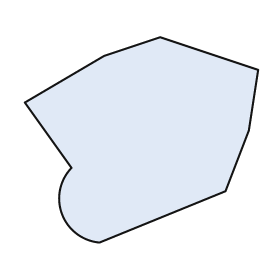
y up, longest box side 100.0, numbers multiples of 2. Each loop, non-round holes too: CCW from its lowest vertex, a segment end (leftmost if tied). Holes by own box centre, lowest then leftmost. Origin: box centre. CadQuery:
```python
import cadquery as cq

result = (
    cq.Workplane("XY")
    .moveTo(-18.0, -44.0)
    .lineTo(36.0, -22.0)
    .lineTo(46.0, 4.0)
    .lineTo(50.0, 30.0)
    .lineTo(8.0, 44.0)
    .lineTo(-16.0, 36.0)
    .lineTo(-50.0, 16.0)
    .lineTo(-30.0, -12.0)
    .threePointArc((-34.0, -32.0), (-18.0, -44.0))
    .close()
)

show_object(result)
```